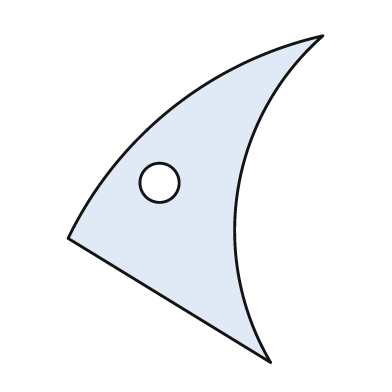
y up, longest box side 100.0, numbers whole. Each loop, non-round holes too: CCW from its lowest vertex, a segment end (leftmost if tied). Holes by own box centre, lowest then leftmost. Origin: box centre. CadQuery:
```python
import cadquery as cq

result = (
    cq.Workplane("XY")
    .moveTo(23.0, -50.0)
    .threePointArc((13.0, 3.0), (39.0, 50.0))
    .threePointArc((-7.0, 28.0), (-39.0, -12.0))
    .close()
    .moveTo(-11.0, 5.0)
    .circle(6.0)
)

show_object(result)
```